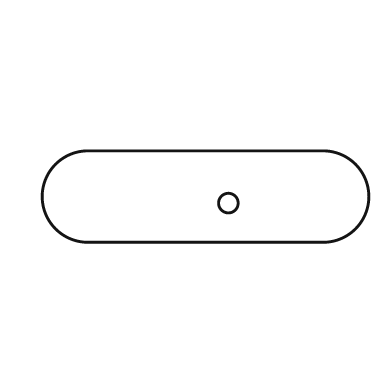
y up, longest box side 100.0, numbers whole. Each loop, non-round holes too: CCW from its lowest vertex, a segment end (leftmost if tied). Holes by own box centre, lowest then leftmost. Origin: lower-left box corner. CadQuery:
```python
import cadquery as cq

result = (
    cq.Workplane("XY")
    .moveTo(14.0, 0.0)
    .lineTo(86.0, 0.0)
    .threePointArc((100.0, 14.0), (86.0, 28.0))
    .lineTo(14.0, 28.0)
    .threePointArc((0.0, 14.0), (14.0, 0.0))
    .close()
    .moveTo(57.0, 12.0)
    .circle(3.0)
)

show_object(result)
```